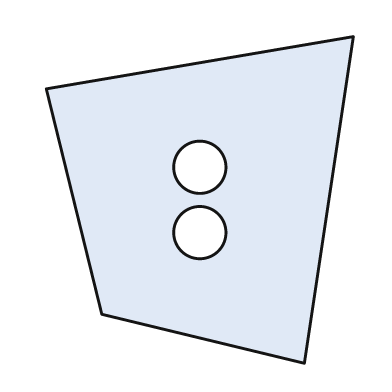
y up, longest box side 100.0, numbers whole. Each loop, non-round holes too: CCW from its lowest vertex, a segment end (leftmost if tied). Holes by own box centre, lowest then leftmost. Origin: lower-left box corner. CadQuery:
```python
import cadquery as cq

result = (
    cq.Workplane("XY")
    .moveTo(79.0, 0.0)
    .lineTo(94.0, 100.0)
    .lineTo(0.0, 84.0)
    .lineTo(17.0, 15.0)
    .close()
    .moveTo(47.0, 40.0)
    .circle(8.0)
    .moveTo(47.0, 60.0)
    .circle(8.0)
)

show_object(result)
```